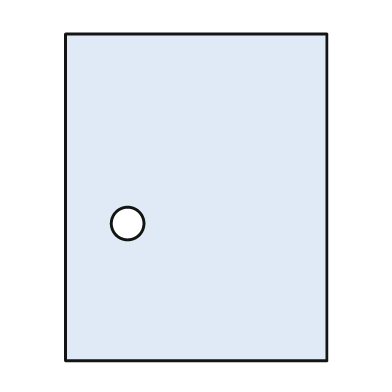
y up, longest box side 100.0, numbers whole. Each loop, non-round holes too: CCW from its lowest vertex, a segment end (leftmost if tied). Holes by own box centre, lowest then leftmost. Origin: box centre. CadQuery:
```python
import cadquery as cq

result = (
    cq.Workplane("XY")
    .moveTo(-40.0, -50.0)
    .lineTo(40.0, -50.0)
    .lineTo(40.0, 50.0)
    .lineTo(-40.0, 50.0)
    .close()
    .moveTo(-21.0, -8.0)
    .circle(5.0)
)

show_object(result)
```